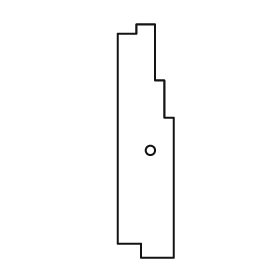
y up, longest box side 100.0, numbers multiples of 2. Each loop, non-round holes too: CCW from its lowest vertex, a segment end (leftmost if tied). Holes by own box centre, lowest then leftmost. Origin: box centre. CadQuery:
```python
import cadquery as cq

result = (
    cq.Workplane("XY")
    .moveTo(-2.0, -50.0)
    .lineTo(12.0, -50.0)
    .lineTo(12.0, 10.0)
    .lineTo(8.0, 10.0)
    .lineTo(8.0, 26.0)
    .lineTo(4.0, 26.0)
    .lineTo(4.0, 50.0)
    .lineTo(-4.0, 50.0)
    .lineTo(-4.0, 46.0)
    .lineTo(-12.0, 46.0)
    .lineTo(-12.0, -44.0)
    .lineTo(-2.0, -44.0)
    .close()
    .moveTo(2.0, -4.0)
    .circle(2.0)
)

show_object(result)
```